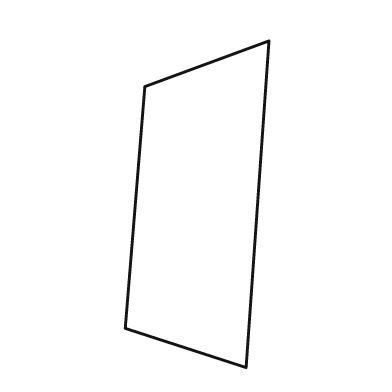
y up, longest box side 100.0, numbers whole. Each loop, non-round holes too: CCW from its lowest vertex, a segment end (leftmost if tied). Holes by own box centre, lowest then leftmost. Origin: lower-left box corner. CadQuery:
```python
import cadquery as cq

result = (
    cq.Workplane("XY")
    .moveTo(37.0, 0.0)
    .lineTo(44.0, 100.0)
    .lineTo(6.0, 86.0)
    .lineTo(0.0, 12.0)
    .close()
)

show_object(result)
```